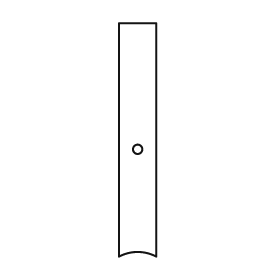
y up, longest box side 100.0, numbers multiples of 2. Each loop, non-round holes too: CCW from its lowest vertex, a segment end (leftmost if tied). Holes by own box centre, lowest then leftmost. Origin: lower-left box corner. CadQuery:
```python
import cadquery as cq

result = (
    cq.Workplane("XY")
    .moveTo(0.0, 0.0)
    .threePointArc((8.0, 2.0), (16.0, 0.0))
    .lineTo(16.0, 100.0)
    .lineTo(0.0, 100.0)
    .close()
    .moveTo(8.0, 46.0)
    .circle(2.0)
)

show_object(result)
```